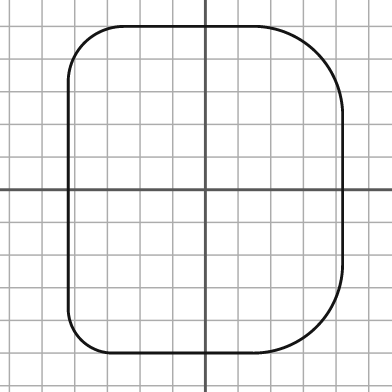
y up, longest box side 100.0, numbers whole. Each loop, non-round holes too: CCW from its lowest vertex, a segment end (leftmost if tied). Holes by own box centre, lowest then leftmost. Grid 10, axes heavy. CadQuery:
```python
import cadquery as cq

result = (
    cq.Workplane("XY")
    .moveTo(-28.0, -50.0)
    .lineTo(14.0, -50.0)
    .threePointArc((34.0, -42.0), (42.0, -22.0))
    .lineTo(42.0, 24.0)
    .threePointArc((34.0, 42.0), (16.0, 50.0))
    .lineTo(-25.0, 50.0)
    .threePointArc((-37.0, 45.0), (-42.0, 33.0))
    .lineTo(-42.0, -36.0)
    .threePointArc((-38.0, -46.0), (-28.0, -50.0))
    .close()
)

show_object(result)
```